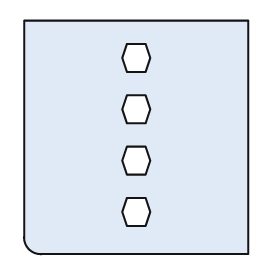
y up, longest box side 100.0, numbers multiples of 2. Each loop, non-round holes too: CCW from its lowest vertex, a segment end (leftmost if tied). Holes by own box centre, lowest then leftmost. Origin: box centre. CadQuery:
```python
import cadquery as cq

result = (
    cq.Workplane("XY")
    .moveTo(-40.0, -50.0)
    .lineTo(48.0, -50.0)
    .lineTo(48.0, 50.0)
    .lineTo(-48.0, 50.0)
    .lineTo(-48.0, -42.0)
    .threePointArc((-46.0, -48.0), (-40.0, -50.0))
    .close()
    .moveTo(-4.0, -38.0)
    .lineTo(4.0, -38.0)
    .lineTo(6.0, -32.0)
    .lineTo(4.0, -26.0)
    .lineTo(-4.0, -26.0)
    .lineTo(-6.0, -32.0)
    .close()
    .moveTo(-4.0, -16.0)
    .lineTo(4.0, -16.0)
    .lineTo(6.0, -10.0)
    .lineTo(4.0, -4.0)
    .lineTo(-4.0, -4.0)
    .lineTo(-6.0, -10.0)
    .close()
    .moveTo(-4.0, 6.0)
    .lineTo(4.0, 6.0)
    .lineTo(6.0, 12.0)
    .lineTo(4.0, 18.0)
    .lineTo(-4.0, 18.0)
    .lineTo(-6.0, 12.0)
    .close()
    .moveTo(-4.0, 28.0)
    .lineTo(4.0, 28.0)
    .lineTo(6.0, 34.0)
    .lineTo(4.0, 40.0)
    .lineTo(-4.0, 40.0)
    .lineTo(-6.0, 34.0)
    .close()
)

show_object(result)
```